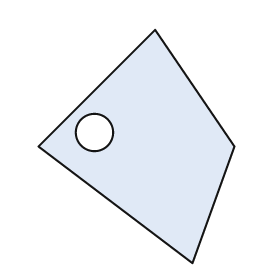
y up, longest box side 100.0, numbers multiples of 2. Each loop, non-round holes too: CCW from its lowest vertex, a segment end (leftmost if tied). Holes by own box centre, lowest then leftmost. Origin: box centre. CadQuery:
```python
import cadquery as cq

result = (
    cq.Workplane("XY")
    .moveTo(24.0, -50.0)
    .lineTo(42.0, 0.0)
    .lineTo(8.0, 50.0)
    .lineTo(-42.0, 0.0)
    .close()
    .moveTo(-18.0, 6.0)
    .circle(8.0)
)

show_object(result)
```